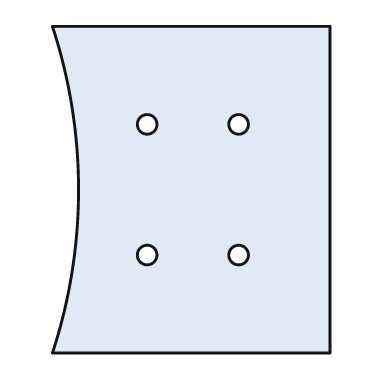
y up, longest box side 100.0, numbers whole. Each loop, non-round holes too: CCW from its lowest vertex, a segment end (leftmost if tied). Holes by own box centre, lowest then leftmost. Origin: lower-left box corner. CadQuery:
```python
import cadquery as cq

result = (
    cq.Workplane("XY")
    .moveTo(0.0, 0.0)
    .lineTo(85.0, 0.0)
    .lineTo(85.0, 100.0)
    .lineTo(0.0, 100.0)
    .threePointArc((8.0, 50.0), (0.0, 0.0))
    .close()
    .moveTo(29.0, 30.0)
    .circle(3.0)
    .moveTo(57.0, 30.0)
    .circle(3.0)
    .moveTo(29.0, 70.0)
    .circle(3.0)
    .moveTo(57.0, 70.0)
    .circle(3.0)
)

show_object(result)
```